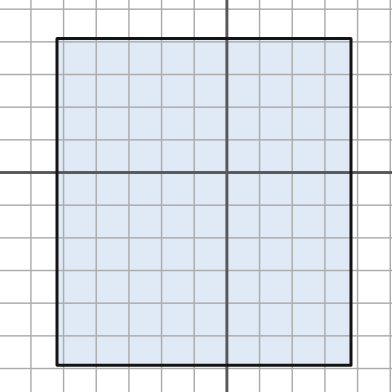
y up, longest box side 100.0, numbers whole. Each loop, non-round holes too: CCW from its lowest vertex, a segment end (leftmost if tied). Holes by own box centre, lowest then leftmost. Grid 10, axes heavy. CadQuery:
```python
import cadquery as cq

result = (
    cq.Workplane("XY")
    .moveTo(-52.0, -59.0)
    .lineTo(38.0, -59.0)
    .lineTo(38.0, 41.0)
    .lineTo(-52.0, 41.0)
    .close()
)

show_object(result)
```